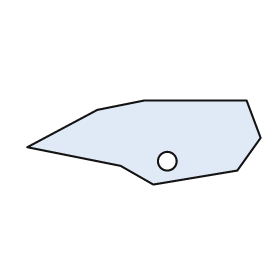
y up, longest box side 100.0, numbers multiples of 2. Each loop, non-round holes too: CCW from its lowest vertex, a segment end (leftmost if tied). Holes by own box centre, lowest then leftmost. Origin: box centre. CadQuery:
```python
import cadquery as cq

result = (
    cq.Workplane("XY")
    .moveTo(4.0, -18.0)
    .lineTo(40.0, -12.0)
    .lineTo(50.0, 2.0)
    .lineTo(44.0, 18.0)
    .lineTo(0.0, 18.0)
    .lineTo(-20.0, 14.0)
    .lineTo(-50.0, -2.0)
    .lineTo(-10.0, -10.0)
    .close()
    .moveTo(10.0, -8.0)
    .circle(4.0)
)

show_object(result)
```